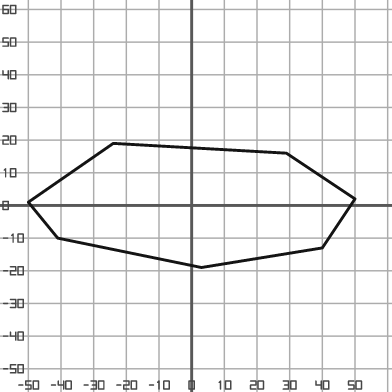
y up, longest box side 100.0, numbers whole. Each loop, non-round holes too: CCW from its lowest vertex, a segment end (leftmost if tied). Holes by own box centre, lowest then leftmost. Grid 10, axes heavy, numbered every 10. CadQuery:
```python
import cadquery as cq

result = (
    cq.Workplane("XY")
    .moveTo(3.0, -19.0)
    .lineTo(40.0, -13.0)
    .lineTo(50.0, 2.0)
    .lineTo(29.0, 16.0)
    .lineTo(-24.0, 19.0)
    .lineTo(-50.0, 1.0)
    .lineTo(-41.0, -10.0)
    .close()
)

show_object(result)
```